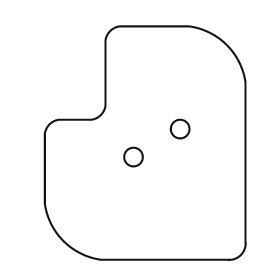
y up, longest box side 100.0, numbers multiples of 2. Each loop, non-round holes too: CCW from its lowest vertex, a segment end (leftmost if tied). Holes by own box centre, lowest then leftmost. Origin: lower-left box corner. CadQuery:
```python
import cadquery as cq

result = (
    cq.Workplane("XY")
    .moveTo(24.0, 0.0)
    .lineTo(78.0, 0.0)
    .threePointArc((84.0, 2.0), (86.0, 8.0))
    .lineTo(86.0, 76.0)
    .threePointArc((78.0, 92.0), (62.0, 100.0))
    .lineTo(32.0, 100.0)
    .threePointArc((28.0, 98.0), (26.0, 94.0))
    .lineTo(26.0, 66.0)
    .threePointArc((24.0, 62.0), (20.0, 60.0))
    .lineTo(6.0, 60.0)
    .threePointArc((2.0, 58.0), (0.0, 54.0))
    .lineTo(0.0, 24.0)
    .threePointArc((8.0, 8.0), (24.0, 0.0))
    .close()
    .moveTo(38.0, 44.0)
    .circle(4.0)
    .moveTo(58.0, 56.0)
    .circle(4.0)
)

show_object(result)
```